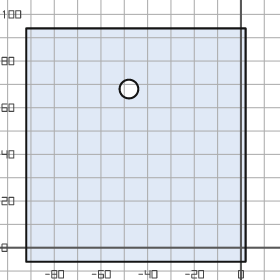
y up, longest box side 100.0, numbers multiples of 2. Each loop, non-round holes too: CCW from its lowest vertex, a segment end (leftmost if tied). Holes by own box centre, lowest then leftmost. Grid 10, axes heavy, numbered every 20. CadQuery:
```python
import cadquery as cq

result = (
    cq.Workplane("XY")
    .moveTo(-92.0, -6.0)
    .lineTo(2.0, -6.0)
    .lineTo(2.0, 94.0)
    .lineTo(-92.0, 94.0)
    .close()
    .moveTo(-48.0, 68.0)
    .circle(4.0)
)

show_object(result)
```